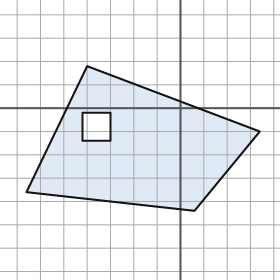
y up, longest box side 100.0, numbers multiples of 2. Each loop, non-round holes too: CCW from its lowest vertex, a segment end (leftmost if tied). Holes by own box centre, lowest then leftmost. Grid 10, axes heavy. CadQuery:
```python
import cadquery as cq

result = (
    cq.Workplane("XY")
    .moveTo(6.0, -44.0)
    .lineTo(34.0, -10.0)
    .lineTo(-40.0, 18.0)
    .lineTo(-66.0, -36.0)
    .close()
    .moveTo(-42.0, -14.0)
    .lineTo(-30.0, -14.0)
    .lineTo(-30.0, -2.0)
    .lineTo(-42.0, -2.0)
    .close()
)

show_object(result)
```